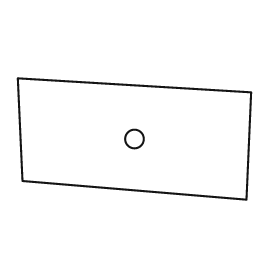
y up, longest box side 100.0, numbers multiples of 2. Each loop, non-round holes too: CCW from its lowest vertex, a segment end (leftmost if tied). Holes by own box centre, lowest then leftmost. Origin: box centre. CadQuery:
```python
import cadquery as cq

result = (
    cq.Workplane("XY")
    .moveTo(48.0, -26.0)
    .lineTo(50.0, 20.0)
    .lineTo(-50.0, 26.0)
    .lineTo(-48.0, -18.0)
    .close()
    .moveTo(0.0, 0.0)
    .circle(4.0)
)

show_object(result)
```